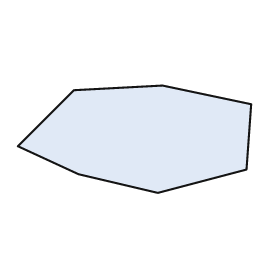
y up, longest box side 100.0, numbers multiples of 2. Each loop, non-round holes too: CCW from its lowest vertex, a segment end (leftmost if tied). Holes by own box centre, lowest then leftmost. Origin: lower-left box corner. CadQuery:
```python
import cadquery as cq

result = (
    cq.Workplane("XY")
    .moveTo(60.0, 0.0)
    .lineTo(98.0, 10.0)
    .lineTo(100.0, 38.0)
    .lineTo(62.0, 46.0)
    .lineTo(24.0, 44.0)
    .lineTo(0.0, 20.0)
    .lineTo(26.0, 8.0)
    .close()
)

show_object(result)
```